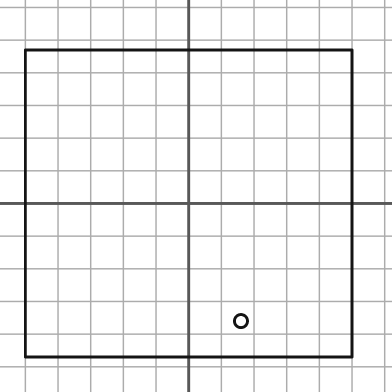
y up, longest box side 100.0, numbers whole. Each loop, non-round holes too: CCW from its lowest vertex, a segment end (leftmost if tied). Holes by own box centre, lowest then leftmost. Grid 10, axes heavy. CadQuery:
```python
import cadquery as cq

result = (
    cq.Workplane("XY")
    .moveTo(-50.0, -47.0)
    .lineTo(50.0, -47.0)
    .lineTo(50.0, 47.0)
    .lineTo(-50.0, 47.0)
    .close()
    .moveTo(16.0, -36.0)
    .circle(2.0)
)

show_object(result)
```